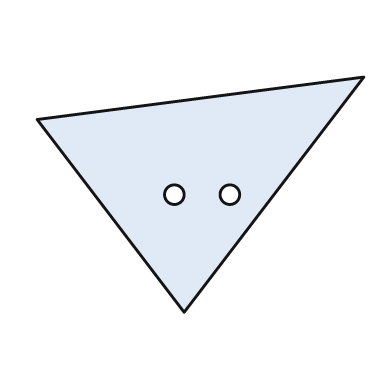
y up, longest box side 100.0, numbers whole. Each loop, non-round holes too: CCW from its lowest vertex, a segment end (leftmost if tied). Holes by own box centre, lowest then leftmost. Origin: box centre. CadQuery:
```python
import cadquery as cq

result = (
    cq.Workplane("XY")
    .moveTo(-5.0, -36.0)
    .lineTo(50.0, 36.0)
    .lineTo(-50.0, 23.0)
    .close()
    .moveTo(-8.0, 0.0)
    .circle(3.0)
    .moveTo(9.0, 0.0)
    .circle(3.0)
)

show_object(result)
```